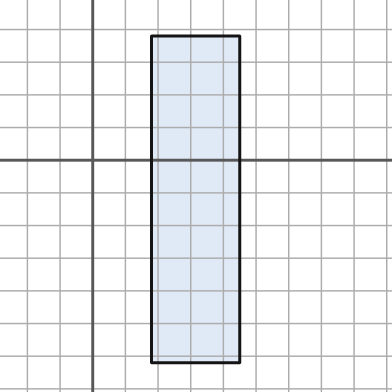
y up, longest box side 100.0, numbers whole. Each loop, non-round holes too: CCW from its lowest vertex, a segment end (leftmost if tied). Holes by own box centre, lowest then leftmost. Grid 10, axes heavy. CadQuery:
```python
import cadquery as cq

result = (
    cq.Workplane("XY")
    .moveTo(18.0, -62.0)
    .lineTo(45.0, -62.0)
    .lineTo(45.0, 38.0)
    .lineTo(18.0, 38.0)
    .close()
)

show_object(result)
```